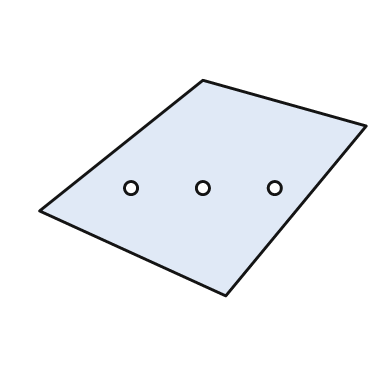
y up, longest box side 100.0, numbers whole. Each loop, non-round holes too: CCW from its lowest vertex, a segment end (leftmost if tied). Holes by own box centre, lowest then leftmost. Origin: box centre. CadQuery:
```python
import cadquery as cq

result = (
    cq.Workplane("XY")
    .moveTo(7.0, -33.0)
    .lineTo(50.0, 19.0)
    .lineTo(0.0, 33.0)
    .lineTo(-50.0, -7.0)
    .close()
    .moveTo(-22.0, 0.0)
    .circle(2.0)
    .moveTo(0.0, 0.0)
    .circle(2.0)
    .moveTo(22.0, 0.0)
    .circle(2.0)
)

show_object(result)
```